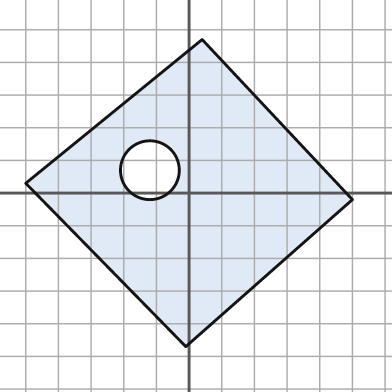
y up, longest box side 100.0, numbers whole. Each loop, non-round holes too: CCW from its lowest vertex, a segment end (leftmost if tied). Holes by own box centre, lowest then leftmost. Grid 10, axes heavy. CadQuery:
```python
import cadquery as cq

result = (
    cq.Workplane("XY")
    .moveTo(-1.0, -47.0)
    .lineTo(50.0, -2.0)
    .lineTo(4.0, 47.0)
    .lineTo(-50.0, 3.0)
    .close()
    .moveTo(-12.0, 7.0)
    .circle(9.0)
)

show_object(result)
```